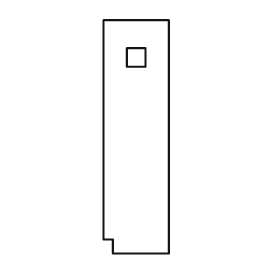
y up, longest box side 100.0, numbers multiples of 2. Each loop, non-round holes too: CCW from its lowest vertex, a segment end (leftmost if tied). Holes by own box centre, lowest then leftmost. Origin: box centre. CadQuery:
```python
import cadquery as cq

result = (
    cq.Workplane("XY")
    .moveTo(-10.0, -50.0)
    .lineTo(14.0, -50.0)
    .lineTo(14.0, 50.0)
    .lineTo(-14.0, 50.0)
    .lineTo(-14.0, -44.0)
    .lineTo(-10.0, -44.0)
    .close()
    .moveTo(-4.0, 30.0)
    .lineTo(4.0, 30.0)
    .lineTo(4.0, 38.0)
    .lineTo(-4.0, 38.0)
    .close()
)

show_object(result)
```